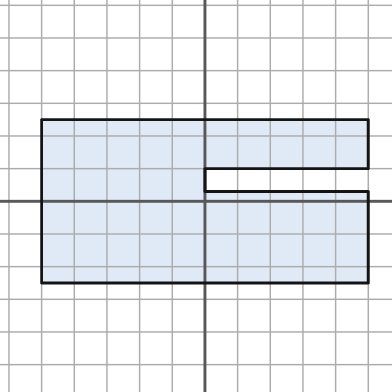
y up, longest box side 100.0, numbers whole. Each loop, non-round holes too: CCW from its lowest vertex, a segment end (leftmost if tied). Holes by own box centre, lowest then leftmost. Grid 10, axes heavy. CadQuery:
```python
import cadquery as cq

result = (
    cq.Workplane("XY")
    .moveTo(-50.0, -25.0)
    .lineTo(50.0, -25.0)
    .lineTo(50.0, 3.0)
    .lineTo(0.0, 3.0)
    .lineTo(0.0, 10.0)
    .lineTo(50.0, 10.0)
    .lineTo(50.0, 25.0)
    .lineTo(-50.0, 25.0)
    .close()
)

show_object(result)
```